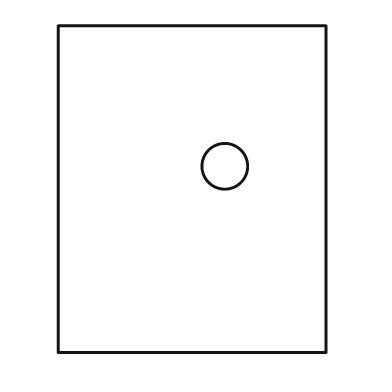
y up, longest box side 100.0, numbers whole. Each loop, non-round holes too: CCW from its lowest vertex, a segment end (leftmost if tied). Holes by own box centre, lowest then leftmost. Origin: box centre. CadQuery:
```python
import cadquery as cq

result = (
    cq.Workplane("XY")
    .moveTo(-41.0, -50.0)
    .lineTo(41.0, -50.0)
    .lineTo(41.0, 50.0)
    .lineTo(-41.0, 50.0)
    .close()
    .moveTo(10.0, 7.0)
    .circle(7.0)
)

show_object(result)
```